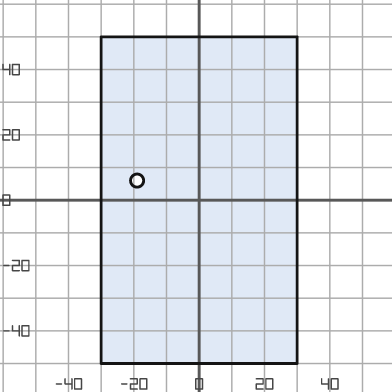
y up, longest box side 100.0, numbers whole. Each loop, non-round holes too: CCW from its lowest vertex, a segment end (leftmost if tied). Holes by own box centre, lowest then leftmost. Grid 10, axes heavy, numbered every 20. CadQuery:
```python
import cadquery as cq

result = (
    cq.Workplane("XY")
    .moveTo(-30.0, -50.0)
    .lineTo(30.0, -50.0)
    .lineTo(30.0, 50.0)
    .lineTo(-30.0, 50.0)
    .close()
    .moveTo(-19.0, 6.0)
    .circle(2.0)
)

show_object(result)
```